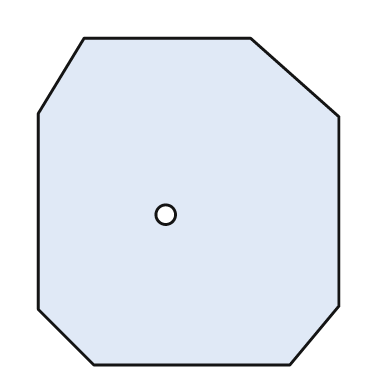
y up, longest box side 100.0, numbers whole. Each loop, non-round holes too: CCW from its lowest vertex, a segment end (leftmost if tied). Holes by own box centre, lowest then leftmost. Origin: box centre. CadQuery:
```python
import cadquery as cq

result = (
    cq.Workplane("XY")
    .moveTo(-29.0, -50.0)
    .lineTo(31.0, -50.0)
    .lineTo(46.0, -32.0)
    .lineTo(46.0, 26.0)
    .lineTo(19.0, 50.0)
    .lineTo(-32.0, 50.0)
    .lineTo(-46.0, 27.0)
    .lineTo(-46.0, -33.0)
    .close()
    .moveTo(-7.0, -4.0)
    .circle(3.0)
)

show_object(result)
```